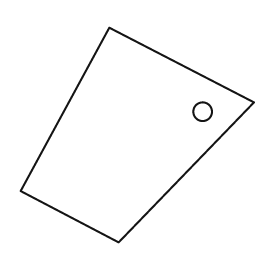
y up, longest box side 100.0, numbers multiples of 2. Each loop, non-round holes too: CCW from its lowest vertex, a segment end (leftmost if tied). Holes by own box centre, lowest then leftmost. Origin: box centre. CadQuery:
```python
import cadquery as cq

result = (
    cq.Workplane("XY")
    .moveTo(-8.0, -46.0)
    .lineTo(50.0, 14.0)
    .lineTo(-12.0, 46.0)
    .lineTo(-50.0, -24.0)
    .close()
    .moveTo(28.0, 10.0)
    .circle(4.0)
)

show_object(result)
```